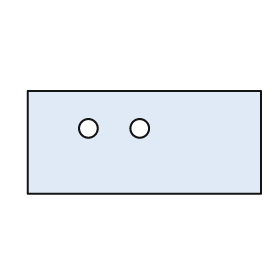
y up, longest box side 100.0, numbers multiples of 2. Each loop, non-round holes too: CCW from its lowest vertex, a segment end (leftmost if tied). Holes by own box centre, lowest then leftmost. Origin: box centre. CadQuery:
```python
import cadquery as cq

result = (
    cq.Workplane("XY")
    .moveTo(-50.0, -22.0)
    .lineTo(50.0, -22.0)
    .lineTo(50.0, 22.0)
    .lineTo(-50.0, 22.0)
    .close()
    .moveTo(-24.0, 6.0)
    .circle(4.0)
    .moveTo(-2.0, 6.0)
    .circle(4.0)
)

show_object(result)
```